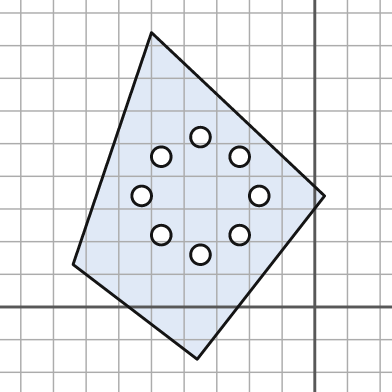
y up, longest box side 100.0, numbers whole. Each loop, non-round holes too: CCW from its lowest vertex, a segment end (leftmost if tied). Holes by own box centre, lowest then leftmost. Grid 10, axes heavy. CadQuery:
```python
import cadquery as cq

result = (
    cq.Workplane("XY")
    .moveTo(-36.0, -16.0)
    .lineTo(3.0, 34.0)
    .lineTo(-50.0, 84.0)
    .lineTo(-74.0, 13.0)
    .close()
    .moveTo(-35.0, 16.0)
    .circle(3.0)
    .moveTo(-47.0, 22.0)
    .circle(3.0)
    .moveTo(-23.0, 22.0)
    .circle(3.0)
    .moveTo(-53.0, 34.0)
    .circle(3.0)
    .moveTo(-17.0, 34.0)
    .circle(3.0)
    .moveTo(-47.0, 46.0)
    .circle(3.0)
    .moveTo(-23.0, 46.0)
    .circle(3.0)
    .moveTo(-35.0, 52.0)
    .circle(3.0)
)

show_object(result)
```